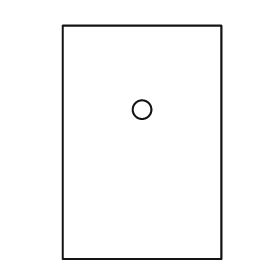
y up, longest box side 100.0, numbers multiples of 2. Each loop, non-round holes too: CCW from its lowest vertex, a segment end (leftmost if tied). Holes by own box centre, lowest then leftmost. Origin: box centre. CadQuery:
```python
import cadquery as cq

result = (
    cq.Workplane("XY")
    .moveTo(-34.0, -50.0)
    .lineTo(34.0, -50.0)
    .lineTo(34.0, 50.0)
    .lineTo(-34.0, 50.0)
    .close()
    .moveTo(0.0, 14.0)
    .circle(4.0)
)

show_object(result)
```